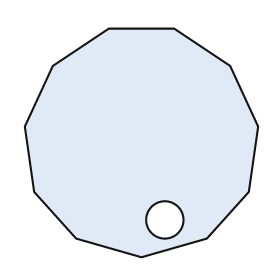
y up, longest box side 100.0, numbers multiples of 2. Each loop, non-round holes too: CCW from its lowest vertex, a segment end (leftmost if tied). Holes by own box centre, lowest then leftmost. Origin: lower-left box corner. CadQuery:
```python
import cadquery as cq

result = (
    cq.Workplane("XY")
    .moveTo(50.0, 0.0)
    .lineTo(78.0, 8.0)
    .lineTo(96.0, 28.0)
    .lineTo(100.0, 56.0)
    .lineTo(88.0, 82.0)
    .lineTo(64.0, 98.0)
    .lineTo(36.0, 98.0)
    .lineTo(12.0, 82.0)
    .lineTo(0.0, 56.0)
    .lineTo(4.0, 28.0)
    .lineTo(22.0, 8.0)
    .close()
    .moveTo(60.0, 16.0)
    .circle(8.0)
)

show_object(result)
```